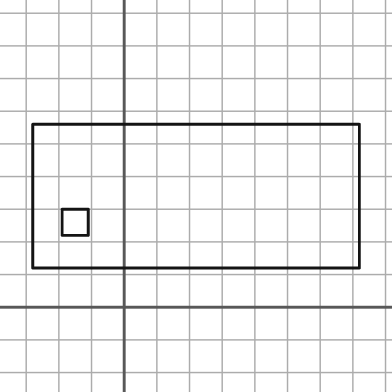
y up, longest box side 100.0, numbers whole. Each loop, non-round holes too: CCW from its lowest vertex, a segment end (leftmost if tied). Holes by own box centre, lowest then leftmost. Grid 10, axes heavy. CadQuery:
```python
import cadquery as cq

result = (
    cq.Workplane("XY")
    .moveTo(-28.0, 12.0)
    .lineTo(72.0, 12.0)
    .lineTo(72.0, 56.0)
    .lineTo(-28.0, 56.0)
    .close()
    .moveTo(-19.0, 22.0)
    .lineTo(-11.0, 22.0)
    .lineTo(-11.0, 30.0)
    .lineTo(-19.0, 30.0)
    .close()
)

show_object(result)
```